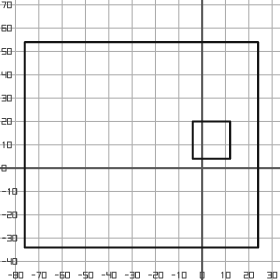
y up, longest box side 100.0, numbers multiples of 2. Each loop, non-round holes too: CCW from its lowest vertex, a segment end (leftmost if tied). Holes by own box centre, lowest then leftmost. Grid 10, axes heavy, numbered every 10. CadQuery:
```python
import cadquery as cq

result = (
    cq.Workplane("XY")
    .moveTo(-76.0, -34.0)
    .lineTo(24.0, -34.0)
    .lineTo(24.0, 54.0)
    .lineTo(-76.0, 54.0)
    .close()
    .moveTo(-4.0, 4.0)
    .lineTo(12.0, 4.0)
    .lineTo(12.0, 20.0)
    .lineTo(-4.0, 20.0)
    .close()
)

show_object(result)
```